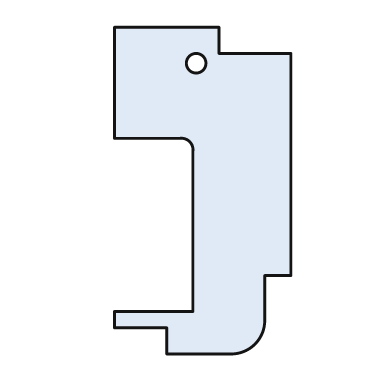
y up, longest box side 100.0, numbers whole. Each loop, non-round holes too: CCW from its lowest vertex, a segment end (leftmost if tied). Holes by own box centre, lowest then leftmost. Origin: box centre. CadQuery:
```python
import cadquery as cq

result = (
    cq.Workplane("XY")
    .moveTo(-11.0, -50.0)
    .lineTo(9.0, -50.0)
    .threePointArc((16.0, -47.0), (19.0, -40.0))
    .lineTo(19.0, -26.0)
    .lineTo(27.0, -26.0)
    .lineTo(27.0, 42.0)
    .lineTo(5.0, 42.0)
    .lineTo(5.0, 50.0)
    .lineTo(-27.0, 50.0)
    .lineTo(-27.0, 16.0)
    .lineTo(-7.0, 16.0)
    .threePointArc((-4.0, 15.0), (-3.0, 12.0))
    .lineTo(-3.0, -37.0)
    .lineTo(-27.0, -37.0)
    .lineTo(-27.0, -42.0)
    .lineTo(-11.0, -42.0)
    .close()
    .moveTo(-2.0, 39.0)
    .circle(3.0)
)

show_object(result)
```